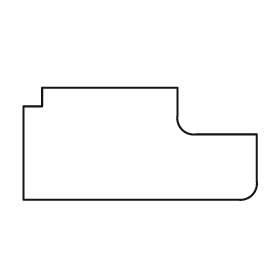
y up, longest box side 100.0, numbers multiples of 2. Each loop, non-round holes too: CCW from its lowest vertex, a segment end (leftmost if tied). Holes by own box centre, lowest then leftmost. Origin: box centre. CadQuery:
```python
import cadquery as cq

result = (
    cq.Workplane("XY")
    .moveTo(-50.0, -24.0)
    .lineTo(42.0, -24.0)
    .threePointArc((48.0, -22.0), (50.0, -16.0))
    .lineTo(50.0, 4.0)
    .lineTo(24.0, 4.0)
    .threePointArc((18.0, 6.0), (16.0, 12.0))
    .lineTo(16.0, 24.0)
    .lineTo(-42.0, 24.0)
    .lineTo(-42.0, 16.0)
    .lineTo(-50.0, 16.0)
    .close()
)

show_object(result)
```